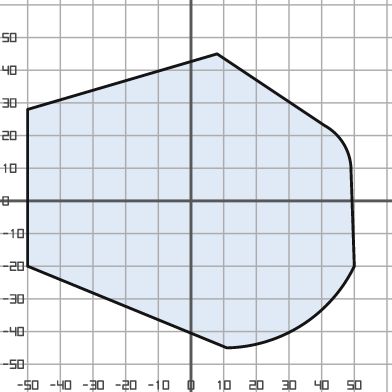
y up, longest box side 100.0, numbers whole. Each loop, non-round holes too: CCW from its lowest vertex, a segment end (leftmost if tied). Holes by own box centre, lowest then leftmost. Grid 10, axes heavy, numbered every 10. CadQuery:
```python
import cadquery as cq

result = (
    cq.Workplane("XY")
    .moveTo(11.0, -45.0)
    .threePointArc((34.0, -38.0), (50.0, -20.0))
    .lineTo(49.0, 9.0)
    .threePointArc((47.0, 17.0), (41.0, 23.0))
    .lineTo(8.0, 45.0)
    .lineTo(-50.0, 28.0)
    .lineTo(-50.0, -20.0)
    .close()
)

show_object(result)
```